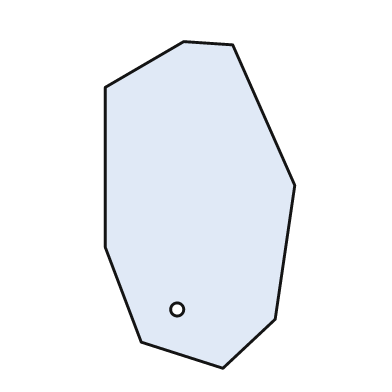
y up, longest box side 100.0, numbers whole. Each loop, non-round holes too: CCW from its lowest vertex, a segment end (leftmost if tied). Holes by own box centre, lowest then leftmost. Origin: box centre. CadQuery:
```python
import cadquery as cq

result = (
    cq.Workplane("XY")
    .moveTo(7.0, -50.0)
    .lineTo(23.0, -35.0)
    .lineTo(29.0, 6.0)
    .lineTo(10.0, 49.0)
    .lineTo(-5.0, 50.0)
    .lineTo(-29.0, 36.0)
    .lineTo(-29.0, -13.0)
    .lineTo(-18.0, -42.0)
    .close()
    .moveTo(-7.0, -32.0)
    .circle(2.0)
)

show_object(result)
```